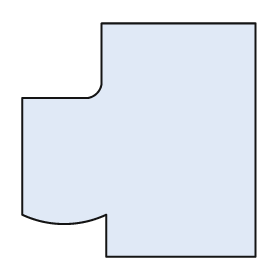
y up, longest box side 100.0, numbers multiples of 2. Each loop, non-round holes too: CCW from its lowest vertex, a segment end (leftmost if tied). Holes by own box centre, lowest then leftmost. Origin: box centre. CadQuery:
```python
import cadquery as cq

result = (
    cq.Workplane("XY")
    .moveTo(-14.0, -50.0)
    .lineTo(50.0, -50.0)
    .lineTo(50.0, 50.0)
    .lineTo(-16.0, 50.0)
    .lineTo(-16.0, 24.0)
    .threePointArc((-18.0, 20.0), (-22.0, 18.0))
    .lineTo(-50.0, 18.0)
    .lineTo(-50.0, -32.0)
    .threePointArc((-32.0, -36.0), (-14.0, -32.0))
    .close()
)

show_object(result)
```